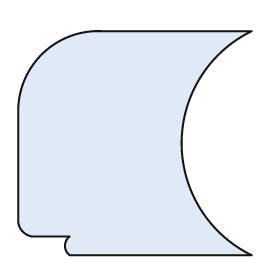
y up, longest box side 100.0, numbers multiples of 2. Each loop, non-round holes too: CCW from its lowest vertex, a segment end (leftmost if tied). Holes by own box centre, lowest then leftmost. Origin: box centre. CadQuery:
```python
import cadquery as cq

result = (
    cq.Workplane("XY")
    .moveTo(-28.0, -48.0)
    .lineTo(50.0, -48.0)
    .threePointArc((20.0, 0.0), (50.0, 48.0))
    .lineTo(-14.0, 48.0)
    .threePointArc((-40.0, 38.0), (-50.0, 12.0))
    .lineTo(-50.0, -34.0)
    .threePointArc((-48.0, -38.0), (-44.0, -40.0))
    .lineTo(-28.0, -40.0)
    .threePointArc((-30.0, -44.0), (-28.0, -48.0))
    .close()
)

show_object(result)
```